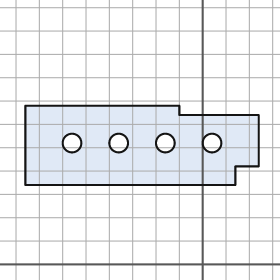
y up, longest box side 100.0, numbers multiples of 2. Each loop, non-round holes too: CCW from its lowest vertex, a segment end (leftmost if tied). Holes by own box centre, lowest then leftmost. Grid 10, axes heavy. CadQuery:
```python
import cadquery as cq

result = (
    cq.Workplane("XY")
    .moveTo(-76.0, 34.0)
    .lineTo(14.0, 34.0)
    .lineTo(14.0, 42.0)
    .lineTo(24.0, 42.0)
    .lineTo(24.0, 64.0)
    .lineTo(-10.0, 64.0)
    .lineTo(-10.0, 68.0)
    .lineTo(-76.0, 68.0)
    .close()
    .moveTo(-56.0, 52.0)
    .circle(4.0)
    .moveTo(-36.0, 52.0)
    .circle(4.0)
    .moveTo(-16.0, 52.0)
    .circle(4.0)
    .moveTo(4.0, 52.0)
    .circle(4.0)
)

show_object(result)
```